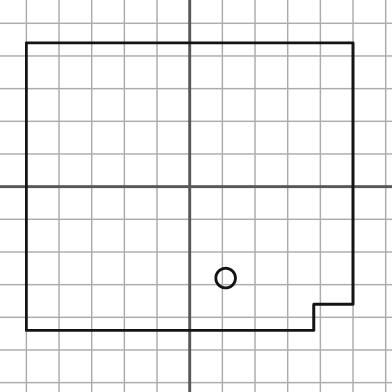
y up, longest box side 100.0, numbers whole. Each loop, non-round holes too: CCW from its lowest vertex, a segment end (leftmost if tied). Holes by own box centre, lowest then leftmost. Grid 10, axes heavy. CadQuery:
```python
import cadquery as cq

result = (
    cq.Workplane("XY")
    .moveTo(-50.0, -44.0)
    .lineTo(38.0, -44.0)
    .lineTo(38.0, -36.0)
    .lineTo(50.0, -36.0)
    .lineTo(50.0, 44.0)
    .lineTo(-50.0, 44.0)
    .close()
    .moveTo(11.0, -28.0)
    .circle(3.0)
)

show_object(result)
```